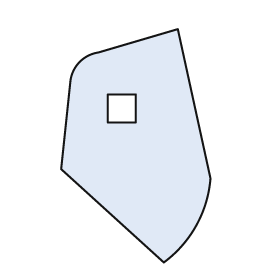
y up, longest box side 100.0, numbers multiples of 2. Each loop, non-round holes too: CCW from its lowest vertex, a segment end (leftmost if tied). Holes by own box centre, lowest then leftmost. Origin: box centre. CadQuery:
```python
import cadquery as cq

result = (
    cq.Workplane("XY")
    .moveTo(12.0, -50.0)
    .threePointArc((26.0, -34.0), (32.0, -14.0))
    .lineTo(18.0, 50.0)
    .lineTo(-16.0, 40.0)
    .threePointArc((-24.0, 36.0), (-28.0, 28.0))
    .lineTo(-32.0, -10.0)
    .close()
    .moveTo(-12.0, 10.0)
    .lineTo(0.0, 10.0)
    .lineTo(0.0, 22.0)
    .lineTo(-12.0, 22.0)
    .close()
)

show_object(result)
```